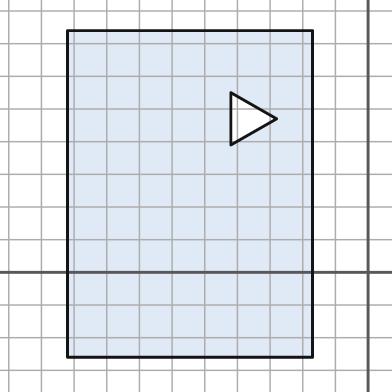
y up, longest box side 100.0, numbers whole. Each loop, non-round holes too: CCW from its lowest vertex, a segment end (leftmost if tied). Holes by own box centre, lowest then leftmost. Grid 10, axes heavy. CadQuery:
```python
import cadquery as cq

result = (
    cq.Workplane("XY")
    .moveTo(-92.0, -26.0)
    .lineTo(-17.0, -26.0)
    .lineTo(-17.0, 74.0)
    .lineTo(-92.0, 74.0)
    .close()
    .moveTo(-42.0, 39.0)
    .lineTo(-28.0, 47.0)
    .lineTo(-42.0, 55.0)
    .close()
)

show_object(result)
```